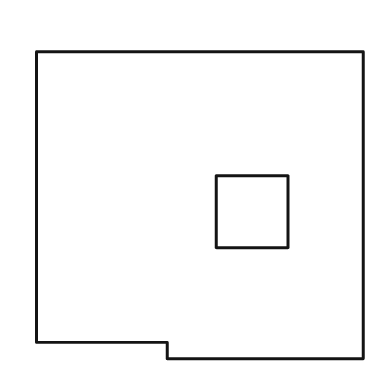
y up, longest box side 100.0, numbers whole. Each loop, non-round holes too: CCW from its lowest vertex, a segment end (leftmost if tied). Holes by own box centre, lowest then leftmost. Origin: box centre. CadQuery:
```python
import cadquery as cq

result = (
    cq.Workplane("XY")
    .moveTo(-10.0, -47.0)
    .lineTo(50.0, -47.0)
    .lineTo(50.0, 47.0)
    .lineTo(-50.0, 47.0)
    .lineTo(-50.0, -42.0)
    .lineTo(-10.0, -42.0)
    .close()
    .moveTo(5.0, -13.0)
    .lineTo(27.0, -13.0)
    .lineTo(27.0, 9.0)
    .lineTo(5.0, 9.0)
    .close()
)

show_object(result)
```